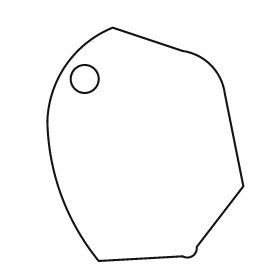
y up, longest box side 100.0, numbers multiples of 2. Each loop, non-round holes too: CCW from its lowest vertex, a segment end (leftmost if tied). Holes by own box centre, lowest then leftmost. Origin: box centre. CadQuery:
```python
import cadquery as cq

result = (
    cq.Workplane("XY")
    .moveTo(-20.0, -50.0)
    .lineTo(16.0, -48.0)
    .threePointArc((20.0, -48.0), (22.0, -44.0))
    .lineTo(42.0, -18.0)
    .lineTo(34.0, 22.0)
    .threePointArc((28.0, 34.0), (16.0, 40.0))
    .lineTo(-14.0, 50.0)
    .threePointArc((-34.0, 34.0), (-42.0, 10.0))
    .threePointArc((-36.0, -22.0), (-20.0, -50.0))
    .close()
    .moveTo(-26.0, 28.0)
    .circle(6.0)
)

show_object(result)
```